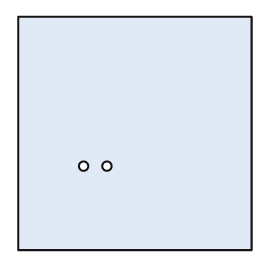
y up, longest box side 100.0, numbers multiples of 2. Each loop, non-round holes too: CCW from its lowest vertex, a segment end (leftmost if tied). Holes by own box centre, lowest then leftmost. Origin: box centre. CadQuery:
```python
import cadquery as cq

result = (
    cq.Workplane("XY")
    .moveTo(-50.0, -50.0)
    .lineTo(50.0, -50.0)
    .lineTo(50.0, 50.0)
    .lineTo(-50.0, 50.0)
    .close()
    .moveTo(-22.0, -14.0)
    .circle(2.0)
    .moveTo(-12.0, -14.0)
    .circle(2.0)
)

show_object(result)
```